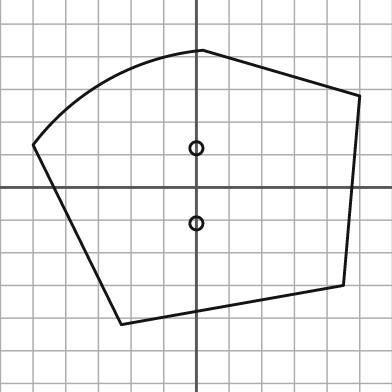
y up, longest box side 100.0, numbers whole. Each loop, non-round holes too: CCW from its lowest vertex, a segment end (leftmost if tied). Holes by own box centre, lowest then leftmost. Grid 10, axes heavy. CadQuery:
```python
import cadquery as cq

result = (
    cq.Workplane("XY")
    .moveTo(-23.0, -42.0)
    .lineTo(45.0, -30.0)
    .lineTo(50.0, 28.0)
    .lineTo(2.0, 42.0)
    .threePointArc((-27.0, 33.0), (-50.0, 13.0))
    .close()
    .moveTo(0.0, -11.0)
    .circle(2.0)
    .moveTo(0.0, 12.0)
    .circle(2.0)
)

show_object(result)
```